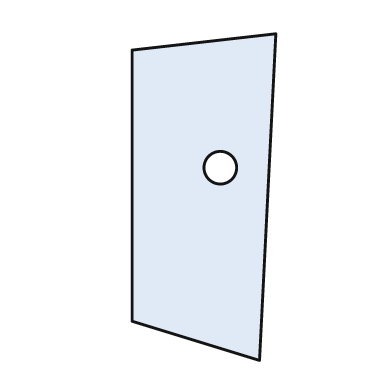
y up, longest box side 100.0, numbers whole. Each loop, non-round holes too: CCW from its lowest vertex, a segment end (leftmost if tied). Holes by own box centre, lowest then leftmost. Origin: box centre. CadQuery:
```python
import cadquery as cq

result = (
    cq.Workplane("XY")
    .moveTo(17.0, -50.0)
    .lineTo(22.0, 50.0)
    .lineTo(-22.0, 45.0)
    .lineTo(-22.0, -38.0)
    .close()
    .moveTo(5.0, 9.0)
    .circle(5.0)
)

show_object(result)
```